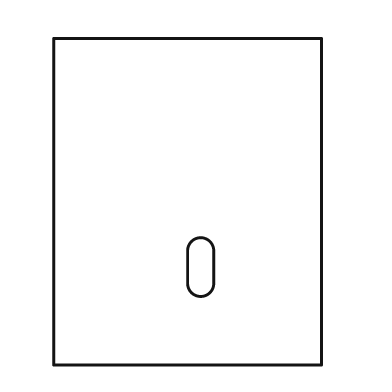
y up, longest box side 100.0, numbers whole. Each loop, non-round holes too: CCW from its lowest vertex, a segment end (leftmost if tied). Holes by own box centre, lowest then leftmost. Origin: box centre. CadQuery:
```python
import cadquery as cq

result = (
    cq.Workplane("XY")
    .moveTo(-41.0, -50.0)
    .lineTo(41.0, -50.0)
    .lineTo(41.0, 50.0)
    .lineTo(-41.0, 50.0)
    .close()
    .moveTo(0.0, -25.0)
    .threePointArc((4.0, -29.0), (8.0, -25.0))
    .lineTo(8.0, -15.0)
    .threePointArc((4.0, -11.0), (0.0, -15.0))
    .close()
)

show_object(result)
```